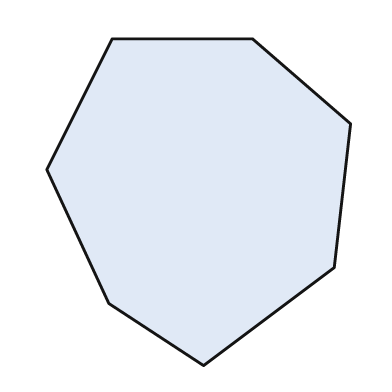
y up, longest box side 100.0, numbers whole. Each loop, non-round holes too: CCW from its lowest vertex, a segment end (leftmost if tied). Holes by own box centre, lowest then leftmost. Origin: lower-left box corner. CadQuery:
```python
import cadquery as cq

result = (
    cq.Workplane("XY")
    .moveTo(48.0, 0.0)
    .lineTo(88.0, 30.0)
    .lineTo(93.0, 74.0)
    .lineTo(63.0, 100.0)
    .lineTo(20.0, 100.0)
    .lineTo(0.0, 60.0)
    .lineTo(19.0, 19.0)
    .close()
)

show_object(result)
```